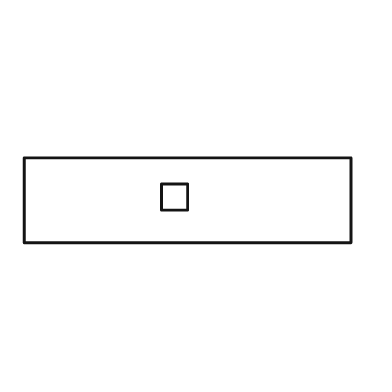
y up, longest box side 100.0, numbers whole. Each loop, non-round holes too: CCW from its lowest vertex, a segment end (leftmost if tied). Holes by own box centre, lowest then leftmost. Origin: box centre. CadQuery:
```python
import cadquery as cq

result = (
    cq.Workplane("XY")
    .moveTo(-50.0, -13.0)
    .lineTo(50.0, -13.0)
    .lineTo(50.0, 13.0)
    .lineTo(-50.0, 13.0)
    .close()
    .moveTo(-8.0, -3.0)
    .lineTo(0.0, -3.0)
    .lineTo(0.0, 5.0)
    .lineTo(-8.0, 5.0)
    .close()
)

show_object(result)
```